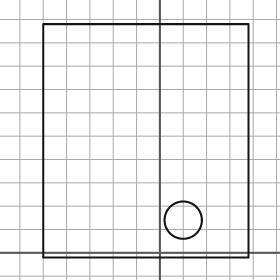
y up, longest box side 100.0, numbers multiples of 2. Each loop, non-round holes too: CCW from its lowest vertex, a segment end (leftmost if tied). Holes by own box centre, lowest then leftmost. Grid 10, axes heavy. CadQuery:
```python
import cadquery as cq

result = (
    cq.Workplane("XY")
    .moveTo(-50.0, -2.0)
    .lineTo(38.0, -2.0)
    .lineTo(38.0, 98.0)
    .lineTo(-50.0, 98.0)
    .close()
    .moveTo(10.0, 14.0)
    .circle(8.0)
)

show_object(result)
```